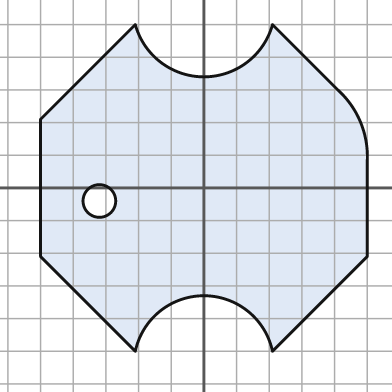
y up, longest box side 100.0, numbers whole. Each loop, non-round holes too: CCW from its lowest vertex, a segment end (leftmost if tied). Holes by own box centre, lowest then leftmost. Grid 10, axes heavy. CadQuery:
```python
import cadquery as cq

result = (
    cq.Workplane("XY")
    .moveTo(-21.0, -50.0)
    .threePointArc((0.0, -33.0), (21.0, -50.0))
    .lineTo(50.0, -21.0)
    .lineTo(50.0, 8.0)
    .threePointArc((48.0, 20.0), (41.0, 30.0))
    .lineTo(21.0, 50.0)
    .threePointArc((0.0, 34.0), (-21.0, 50.0))
    .lineTo(-50.0, 21.0)
    .lineTo(-50.0, -21.0)
    .close()
    .moveTo(-32.0, -4.0)
    .circle(5.0)
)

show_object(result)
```